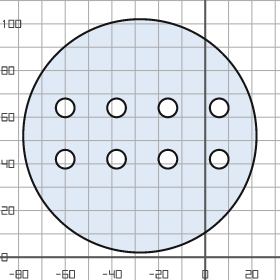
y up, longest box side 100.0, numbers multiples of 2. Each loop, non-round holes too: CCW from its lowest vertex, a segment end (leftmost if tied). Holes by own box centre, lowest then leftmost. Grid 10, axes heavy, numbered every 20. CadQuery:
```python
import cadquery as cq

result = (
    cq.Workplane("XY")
    .moveTo(-28.0, 52.0)
    .circle(50.0)
    .moveTo(-60.0, 42.0)
    .circle(4.0)
    .moveTo(-38.0, 42.0)
    .circle(4.0)
    .moveTo(-16.0, 42.0)
    .circle(4.0)
    .moveTo(6.0, 42.0)
    .circle(4.0)
    .moveTo(-60.0, 64.0)
    .circle(4.0)
    .moveTo(-38.0, 64.0)
    .circle(4.0)
    .moveTo(-16.0, 64.0)
    .circle(4.0)
    .moveTo(6.0, 64.0)
    .circle(4.0)
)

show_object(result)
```